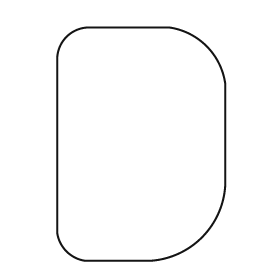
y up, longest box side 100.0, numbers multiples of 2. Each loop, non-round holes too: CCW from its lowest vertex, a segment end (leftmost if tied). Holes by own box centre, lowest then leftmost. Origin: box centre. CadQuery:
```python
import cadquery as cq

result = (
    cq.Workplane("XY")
    .moveTo(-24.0, -50.0)
    .lineTo(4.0, -50.0)
    .threePointArc((26.0, -40.0), (36.0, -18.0))
    .lineTo(36.0, 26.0)
    .threePointArc((28.0, 42.0), (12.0, 50.0))
    .lineTo(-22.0, 50.0)
    .threePointArc((-32.0, 46.0), (-36.0, 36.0))
    .lineTo(-36.0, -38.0)
    .threePointArc((-32.0, -46.0), (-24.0, -50.0))
    .close()
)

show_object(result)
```